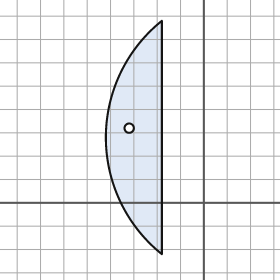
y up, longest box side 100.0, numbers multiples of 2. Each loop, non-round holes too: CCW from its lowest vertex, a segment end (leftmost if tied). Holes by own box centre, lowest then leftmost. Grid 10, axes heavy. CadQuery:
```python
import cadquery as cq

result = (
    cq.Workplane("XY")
    .moveTo(-18.0, -22.0)
    .lineTo(-18.0, 78.0)
    .threePointArc((-42.0, 28.0), (-18.0, -22.0))
    .close()
    .moveTo(-32.0, 32.0)
    .circle(2.0)
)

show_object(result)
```